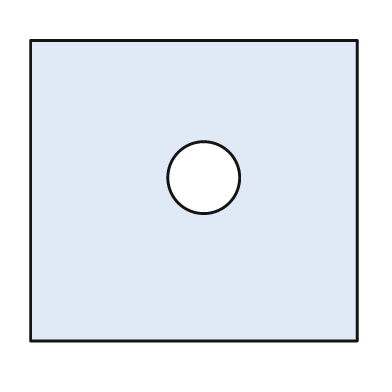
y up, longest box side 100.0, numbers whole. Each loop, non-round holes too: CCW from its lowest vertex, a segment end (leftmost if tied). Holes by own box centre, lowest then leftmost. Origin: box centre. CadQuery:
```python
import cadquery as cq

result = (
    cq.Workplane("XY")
    .moveTo(-50.0, -46.0)
    .lineTo(50.0, -46.0)
    .lineTo(50.0, 46.0)
    .lineTo(-50.0, 46.0)
    .close()
    .moveTo(3.0, 4.0)
    .circle(11.0)
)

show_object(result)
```